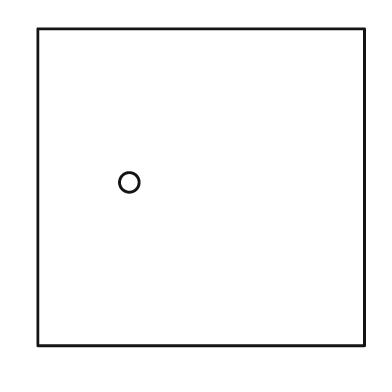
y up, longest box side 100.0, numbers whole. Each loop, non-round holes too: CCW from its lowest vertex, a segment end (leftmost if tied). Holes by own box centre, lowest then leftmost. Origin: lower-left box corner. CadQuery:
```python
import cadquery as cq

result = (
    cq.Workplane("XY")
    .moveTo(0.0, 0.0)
    .lineTo(100.0, 0.0)
    .lineTo(100.0, 97.0)
    .lineTo(0.0, 97.0)
    .close()
    .moveTo(28.0, 50.0)
    .circle(3.0)
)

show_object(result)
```